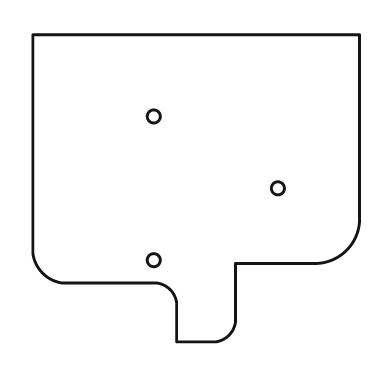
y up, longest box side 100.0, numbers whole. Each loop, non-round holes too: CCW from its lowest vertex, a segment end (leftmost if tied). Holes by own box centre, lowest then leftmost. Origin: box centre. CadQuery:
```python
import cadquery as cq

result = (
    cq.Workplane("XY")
    .moveTo(-6.0, -47.0)
    .lineTo(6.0, -47.0)
    .threePointArc((10.0, -45.0), (12.0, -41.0))
    .lineTo(12.0, -23.0)
    .lineTo(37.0, -23.0)
    .threePointArc((46.0, -19.0), (50.0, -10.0))
    .lineTo(50.0, 47.0)
    .lineTo(-50.0, 47.0)
    .lineTo(-50.0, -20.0)
    .threePointArc((-47.0, -26.0), (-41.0, -29.0))
    .lineTo(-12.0, -29.0)
    .threePointArc((-8.0, -31.0), (-6.0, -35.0))
    .close()
    .moveTo(-13.0, -22.0)
    .circle(2.0)
    .moveTo(25.0, 0.0)
    .circle(2.0)
    .moveTo(-13.0, 22.0)
    .circle(2.0)
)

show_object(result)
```